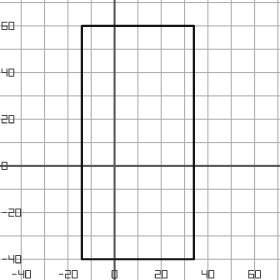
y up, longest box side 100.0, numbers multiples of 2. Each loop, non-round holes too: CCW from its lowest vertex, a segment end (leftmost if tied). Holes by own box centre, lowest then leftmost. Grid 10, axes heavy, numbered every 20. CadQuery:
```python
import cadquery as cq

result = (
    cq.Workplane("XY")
    .moveTo(-14.0, -40.0)
    .lineTo(34.0, -40.0)
    .lineTo(34.0, 60.0)
    .lineTo(-14.0, 60.0)
    .close()
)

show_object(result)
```